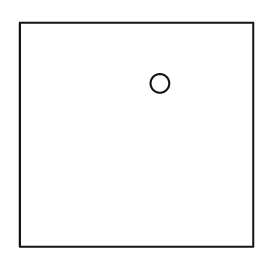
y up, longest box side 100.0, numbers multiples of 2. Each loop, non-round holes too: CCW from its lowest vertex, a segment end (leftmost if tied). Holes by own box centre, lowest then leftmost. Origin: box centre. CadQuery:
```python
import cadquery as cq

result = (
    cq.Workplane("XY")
    .moveTo(-50.0, -48.0)
    .lineTo(50.0, -48.0)
    .lineTo(50.0, 48.0)
    .lineTo(-50.0, 48.0)
    .close()
    .moveTo(10.0, 22.0)
    .circle(4.0)
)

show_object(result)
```